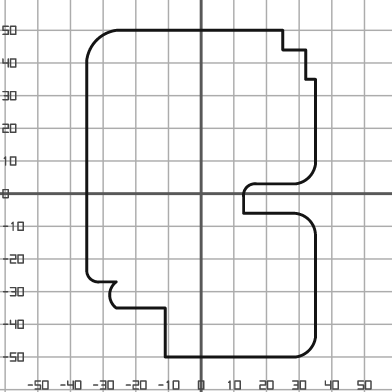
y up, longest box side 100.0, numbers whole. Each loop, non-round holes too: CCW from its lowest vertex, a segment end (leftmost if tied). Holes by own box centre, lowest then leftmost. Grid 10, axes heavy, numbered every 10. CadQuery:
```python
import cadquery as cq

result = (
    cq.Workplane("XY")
    .moveTo(-11.0, -50.0)
    .lineTo(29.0, -50.0)
    .threePointArc((33.0, -48.0), (35.0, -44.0))
    .lineTo(35.0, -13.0)
    .threePointArc((33.0, -8.0), (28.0, -6.0))
    .lineTo(13.0, -6.0)
    .lineTo(13.0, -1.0)
    .threePointArc((14.0, 2.0), (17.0, 3.0))
    .lineTo(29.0, 3.0)
    .threePointArc((33.0, 5.0), (35.0, 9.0))
    .lineTo(35.0, 35.0)
    .lineTo(32.0, 35.0)
    .lineTo(32.0, 44.0)
    .lineTo(25.0, 44.0)
    .lineTo(25.0, 50.0)
    .lineTo(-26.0, 50.0)
    .threePointArc((-32.0, 47.0), (-35.0, 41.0))
    .lineTo(-35.0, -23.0)
    .threePointArc((-34.0, -26.0), (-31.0, -27.0))
    .lineTo(-26.0, -27.0)
    .threePointArc((-28.0, -31.0), (-26.0, -35.0))
    .lineTo(-11.0, -35.0)
    .close()
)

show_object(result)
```